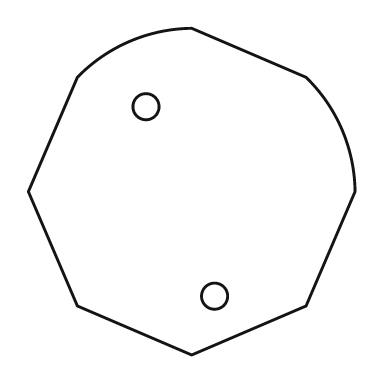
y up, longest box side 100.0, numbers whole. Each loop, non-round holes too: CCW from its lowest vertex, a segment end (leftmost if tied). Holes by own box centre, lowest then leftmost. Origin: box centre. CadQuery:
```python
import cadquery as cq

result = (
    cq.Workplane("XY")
    .moveTo(0.0, -50.0)
    .lineTo(35.0, -35.0)
    .lineTo(50.0, 0.0)
    .threePointArc((46.0, 19.0), (35.0, 35.0))
    .lineTo(0.0, 50.0)
    .threePointArc((-19.0, 46.0), (-35.0, 35.0))
    .lineTo(-50.0, 0.0)
    .lineTo(-35.0, -35.0)
    .close()
    .moveTo(7.0, -32.0)
    .circle(4.0)
    .moveTo(-14.0, 26.0)
    .circle(4.0)
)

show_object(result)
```